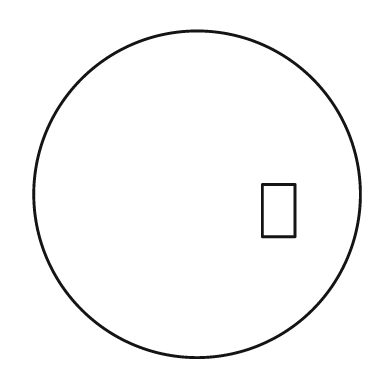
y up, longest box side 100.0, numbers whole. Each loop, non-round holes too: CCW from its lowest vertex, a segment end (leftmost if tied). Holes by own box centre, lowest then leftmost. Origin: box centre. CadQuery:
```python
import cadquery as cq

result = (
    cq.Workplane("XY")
    .moveTo(0.0, 0.0)
    .circle(50.0)
    .moveTo(20.0, -13.0)
    .lineTo(30.0, -13.0)
    .lineTo(30.0, 3.0)
    .lineTo(20.0, 3.0)
    .close()
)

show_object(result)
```